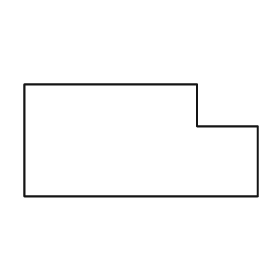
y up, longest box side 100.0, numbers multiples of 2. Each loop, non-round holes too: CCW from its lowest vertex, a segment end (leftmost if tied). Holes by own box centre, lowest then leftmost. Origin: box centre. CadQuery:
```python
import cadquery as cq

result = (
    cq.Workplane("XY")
    .moveTo(-50.0, -24.0)
    .lineTo(50.0, -24.0)
    .lineTo(50.0, 6.0)
    .lineTo(24.0, 6.0)
    .lineTo(24.0, 24.0)
    .lineTo(-50.0, 24.0)
    .close()
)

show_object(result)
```